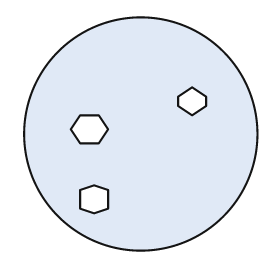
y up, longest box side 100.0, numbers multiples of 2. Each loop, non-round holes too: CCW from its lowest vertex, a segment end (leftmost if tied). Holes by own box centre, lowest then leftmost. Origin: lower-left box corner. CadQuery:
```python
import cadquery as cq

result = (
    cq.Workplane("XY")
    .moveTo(50.0, 50.0)
    .circle(50.0)
    .moveTo(30.0, 16.0)
    .lineTo(36.0, 18.0)
    .lineTo(36.0, 26.0)
    .lineTo(30.0, 28.0)
    .lineTo(24.0, 26.0)
    .lineTo(24.0, 18.0)
    .close()
    .moveTo(24.0, 46.0)
    .lineTo(32.0, 46.0)
    .lineTo(36.0, 52.0)
    .lineTo(32.0, 58.0)
    .lineTo(24.0, 58.0)
    .lineTo(20.0, 52.0)
    .close()
    .moveTo(72.0, 58.0)
    .lineTo(78.0, 62.0)
    .lineTo(78.0, 66.0)
    .lineTo(72.0, 70.0)
    .lineTo(66.0, 66.0)
    .lineTo(66.0, 62.0)
    .close()
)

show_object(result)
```